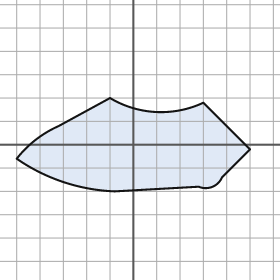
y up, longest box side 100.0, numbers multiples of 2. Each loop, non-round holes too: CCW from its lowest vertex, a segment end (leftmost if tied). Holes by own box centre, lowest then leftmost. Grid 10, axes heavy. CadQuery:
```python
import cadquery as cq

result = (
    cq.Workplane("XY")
    .moveTo(-8.0, -20.0)
    .lineTo(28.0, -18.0)
    .threePointArc((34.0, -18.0), (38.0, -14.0))
    .lineTo(50.0, -2.0)
    .lineTo(30.0, 18.0)
    .threePointArc((10.0, 14.0), (-10.0, 20.0))
    .lineTo(-32.0, 8.0)
    .threePointArc((-42.0, 2.0), (-50.0, -6.0))
    .threePointArc((-30.0, -16.0), (-8.0, -20.0))
    .close()
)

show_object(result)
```